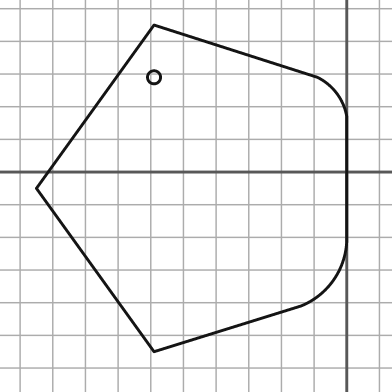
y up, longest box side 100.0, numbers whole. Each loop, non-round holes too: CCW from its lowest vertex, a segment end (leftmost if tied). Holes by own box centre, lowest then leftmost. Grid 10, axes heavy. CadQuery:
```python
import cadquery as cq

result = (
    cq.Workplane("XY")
    .moveTo(-59.0, -55.0)
    .lineTo(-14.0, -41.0)
    .threePointArc((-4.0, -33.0), (0.0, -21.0))
    .lineTo(0.0, 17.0)
    .threePointArc((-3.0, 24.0), (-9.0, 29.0))
    .lineTo(-59.0, 45.0)
    .lineTo(-95.0, -5.0)
    .close()
    .moveTo(-59.0, 29.0)
    .circle(2.0)
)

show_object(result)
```